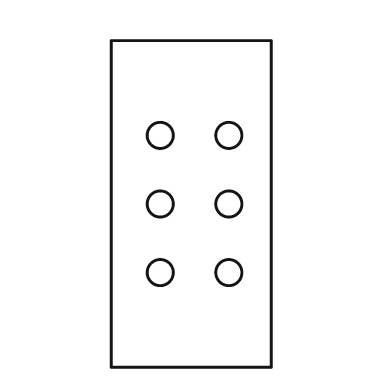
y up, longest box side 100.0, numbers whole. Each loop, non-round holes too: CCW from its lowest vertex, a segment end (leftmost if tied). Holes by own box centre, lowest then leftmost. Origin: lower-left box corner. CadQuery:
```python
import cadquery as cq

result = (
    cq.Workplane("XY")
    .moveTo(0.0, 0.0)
    .lineTo(49.0, 0.0)
    .lineTo(49.0, 100.0)
    .lineTo(0.0, 100.0)
    .close()
    .moveTo(15.0, 29.0)
    .circle(4.0)
    .moveTo(36.0, 29.0)
    .circle(4.0)
    .moveTo(15.0, 50.0)
    .circle(4.0)
    .moveTo(36.0, 50.0)
    .circle(4.0)
    .moveTo(15.0, 71.0)
    .circle(4.0)
    .moveTo(36.0, 71.0)
    .circle(4.0)
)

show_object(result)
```